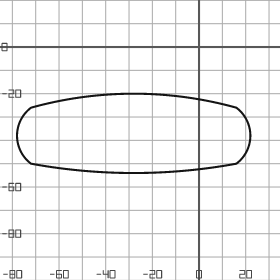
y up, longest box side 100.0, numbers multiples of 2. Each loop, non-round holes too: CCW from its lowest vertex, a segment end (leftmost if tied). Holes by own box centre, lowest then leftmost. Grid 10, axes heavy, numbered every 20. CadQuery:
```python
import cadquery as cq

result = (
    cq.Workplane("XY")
    .moveTo(-72.0, -50.0)
    .threePointArc((-28.0, -54.0), (16.0, -50.0))
    .threePointArc((22.0, -38.0), (16.0, -26.0))
    .threePointArc((-28.0, -20.0), (-72.0, -26.0))
    .threePointArc((-78.0, -38.0), (-72.0, -50.0))
    .close()
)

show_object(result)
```